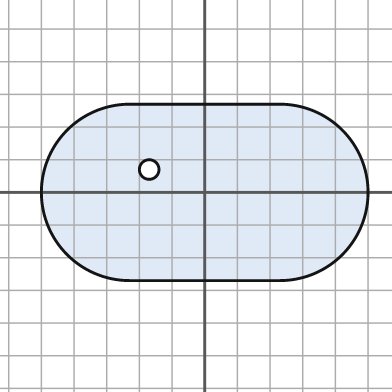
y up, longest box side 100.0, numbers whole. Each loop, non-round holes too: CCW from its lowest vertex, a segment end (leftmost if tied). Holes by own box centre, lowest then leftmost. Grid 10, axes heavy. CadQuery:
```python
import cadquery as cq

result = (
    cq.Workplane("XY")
    .moveTo(-23.0, -27.0)
    .lineTo(23.0, -27.0)
    .threePointArc((50.0, 0.0), (23.0, 27.0))
    .lineTo(-23.0, 27.0)
    .threePointArc((-50.0, 0.0), (-23.0, -27.0))
    .close()
    .moveTo(-17.0, 7.0)
    .circle(3.0)
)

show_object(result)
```